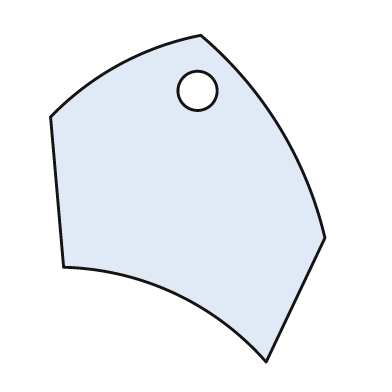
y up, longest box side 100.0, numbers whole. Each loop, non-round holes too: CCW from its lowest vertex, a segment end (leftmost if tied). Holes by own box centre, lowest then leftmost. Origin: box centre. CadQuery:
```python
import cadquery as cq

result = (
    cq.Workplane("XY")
    .moveTo(24.0, -50.0)
    .lineTo(42.0, -12.0)
    .threePointArc((28.0, 22.0), (4.0, 50.0))
    .threePointArc((-21.0, 41.0), (-42.0, 25.0))
    .lineTo(-38.0, -21.0)
    .threePointArc((-4.0, -29.0), (24.0, -50.0))
    .close()
    .moveTo(3.0, 33.0)
    .circle(6.0)
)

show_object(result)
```